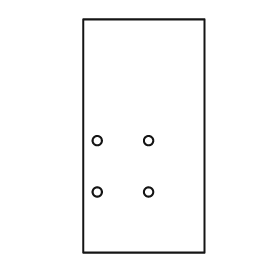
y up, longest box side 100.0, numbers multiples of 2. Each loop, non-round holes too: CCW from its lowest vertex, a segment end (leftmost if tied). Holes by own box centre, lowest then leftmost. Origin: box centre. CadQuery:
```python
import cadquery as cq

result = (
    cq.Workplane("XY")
    .moveTo(-26.0, -50.0)
    .lineTo(26.0, -50.0)
    .lineTo(26.0, 50.0)
    .lineTo(-26.0, 50.0)
    .close()
    .moveTo(-20.0, -24.0)
    .circle(2.0)
    .moveTo(2.0, -24.0)
    .circle(2.0)
    .moveTo(-20.0, -2.0)
    .circle(2.0)
    .moveTo(2.0, -2.0)
    .circle(2.0)
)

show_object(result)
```